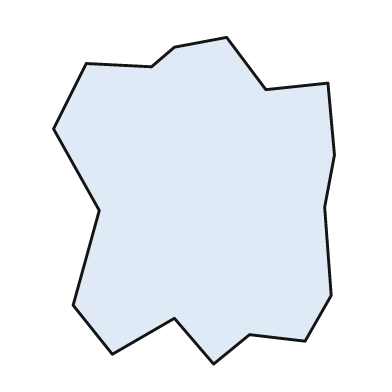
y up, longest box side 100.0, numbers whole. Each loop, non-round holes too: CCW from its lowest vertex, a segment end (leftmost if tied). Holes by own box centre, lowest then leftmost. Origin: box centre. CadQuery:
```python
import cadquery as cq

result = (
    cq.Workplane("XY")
    .moveTo(6.0, -50.0)
    .lineTo(17.0, -41.0)
    .lineTo(34.0, -43.0)
    .lineTo(42.0, -29.0)
    .lineTo(40.0, -2.0)
    .lineTo(43.0, 14.0)
    .lineTo(41.0, 36.0)
    .lineTo(22.0, 34.0)
    .lineTo(10.0, 50.0)
    .lineTo(-6.0, 47.0)
    .lineTo(-13.0, 41.0)
    .lineTo(-33.0, 42.0)
    .lineTo(-43.0, 22.0)
    .lineTo(-29.0, -3.0)
    .lineTo(-37.0, -32.0)
    .lineTo(-25.0, -47.0)
    .lineTo(-6.0, -36.0)
    .close()
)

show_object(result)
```